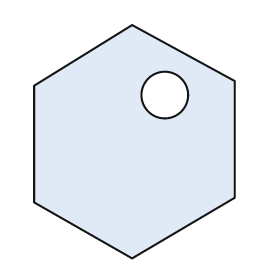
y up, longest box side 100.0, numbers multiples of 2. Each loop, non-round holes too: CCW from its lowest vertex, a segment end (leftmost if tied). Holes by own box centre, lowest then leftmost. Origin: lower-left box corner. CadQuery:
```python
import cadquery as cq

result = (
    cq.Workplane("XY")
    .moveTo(42.0, 0.0)
    .lineTo(86.0, 26.0)
    .lineTo(86.0, 76.0)
    .lineTo(42.0, 100.0)
    .lineTo(0.0, 74.0)
    .lineTo(0.0, 24.0)
    .close()
    .moveTo(56.0, 70.0)
    .circle(10.0)
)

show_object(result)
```